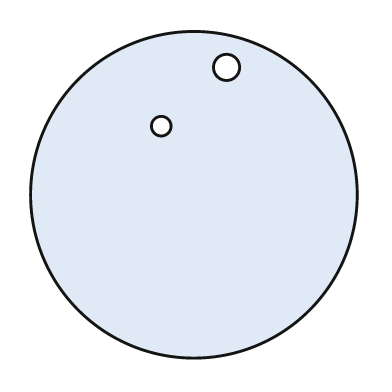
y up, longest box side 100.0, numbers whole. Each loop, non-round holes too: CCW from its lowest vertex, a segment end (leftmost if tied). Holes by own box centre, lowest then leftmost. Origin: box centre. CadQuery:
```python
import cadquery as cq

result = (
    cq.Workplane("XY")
    .moveTo(0.0, 0.0)
    .circle(50.0)
    .moveTo(-10.0, 21.0)
    .circle(3.0)
    .moveTo(10.0, 39.0)
    .circle(4.0)
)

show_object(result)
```